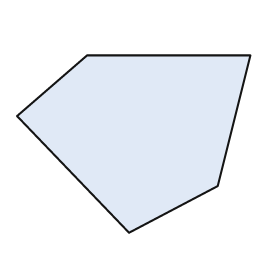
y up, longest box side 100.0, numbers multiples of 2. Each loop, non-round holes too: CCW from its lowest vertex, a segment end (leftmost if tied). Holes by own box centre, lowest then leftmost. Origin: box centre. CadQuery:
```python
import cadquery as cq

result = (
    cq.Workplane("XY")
    .moveTo(-2.0, -38.0)
    .lineTo(36.0, -18.0)
    .lineTo(50.0, 38.0)
    .lineTo(-20.0, 38.0)
    .lineTo(-50.0, 12.0)
    .close()
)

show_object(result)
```